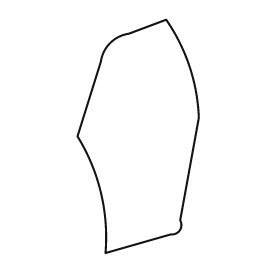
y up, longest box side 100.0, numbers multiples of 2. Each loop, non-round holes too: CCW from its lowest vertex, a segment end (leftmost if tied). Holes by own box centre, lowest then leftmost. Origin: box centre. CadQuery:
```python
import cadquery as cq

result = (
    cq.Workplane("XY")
    .moveTo(-14.0, -50.0)
    .lineTo(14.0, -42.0)
    .threePointArc((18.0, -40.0), (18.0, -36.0))
    .lineTo(26.0, 8.0)
    .threePointArc((22.0, 30.0), (12.0, 50.0))
    .lineTo(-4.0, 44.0)
    .threePointArc((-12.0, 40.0), (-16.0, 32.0))
    .lineTo(-26.0, 0.0)
    .threePointArc((-16.0, -24.0), (-14.0, -50.0))
    .close()
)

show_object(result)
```